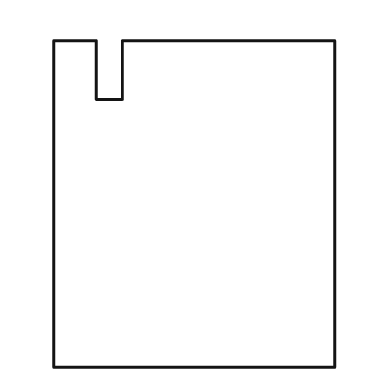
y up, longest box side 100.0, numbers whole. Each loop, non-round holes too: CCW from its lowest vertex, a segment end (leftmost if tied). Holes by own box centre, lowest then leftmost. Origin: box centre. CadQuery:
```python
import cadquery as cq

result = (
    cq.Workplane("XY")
    .moveTo(-43.0, -50.0)
    .lineTo(43.0, -50.0)
    .lineTo(43.0, 50.0)
    .lineTo(-22.0, 50.0)
    .lineTo(-22.0, 32.0)
    .lineTo(-30.0, 32.0)
    .lineTo(-30.0, 50.0)
    .lineTo(-43.0, 50.0)
    .close()
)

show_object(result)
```